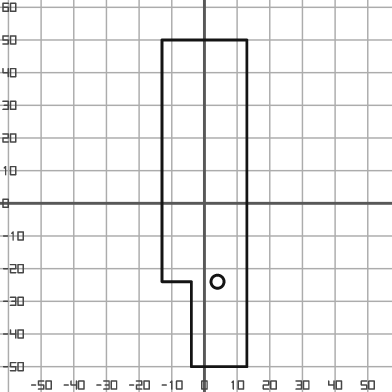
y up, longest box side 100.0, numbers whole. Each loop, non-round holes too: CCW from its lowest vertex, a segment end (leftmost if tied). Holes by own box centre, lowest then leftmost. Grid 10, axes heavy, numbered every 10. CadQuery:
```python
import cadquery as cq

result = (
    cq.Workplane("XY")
    .moveTo(-4.0, -50.0)
    .lineTo(13.0, -50.0)
    .lineTo(13.0, 50.0)
    .lineTo(-13.0, 50.0)
    .lineTo(-13.0, -24.0)
    .lineTo(-4.0, -24.0)
    .close()
    .moveTo(4.0, -24.0)
    .circle(2.0)
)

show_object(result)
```